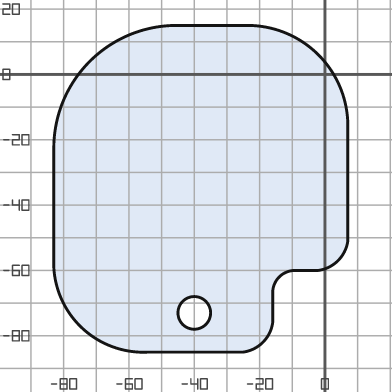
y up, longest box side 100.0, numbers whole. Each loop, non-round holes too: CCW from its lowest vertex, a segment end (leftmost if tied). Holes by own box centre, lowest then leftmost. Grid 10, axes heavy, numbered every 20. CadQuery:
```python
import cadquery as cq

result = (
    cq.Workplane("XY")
    .moveTo(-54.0, -85.0)
    .lineTo(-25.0, -85.0)
    .threePointArc((-19.0, -82.0), (-16.0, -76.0))
    .lineTo(-16.0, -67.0)
    .threePointArc((-14.0, -62.0), (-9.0, -60.0))
    .lineTo(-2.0, -60.0)
    .threePointArc((4.0, -57.0), (7.0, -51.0))
    .lineTo(7.0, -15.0)
    .threePointArc((-2.0, 6.0), (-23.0, 15.0))
    .lineTo(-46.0, 15.0)
    .threePointArc((-72.0, 4.0), (-83.0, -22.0))
    .lineTo(-83.0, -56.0)
    .threePointArc((-75.0, -77.0), (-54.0, -85.0))
    .close()
    .moveTo(-40.0, -73.0)
    .circle(5.0)
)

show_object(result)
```